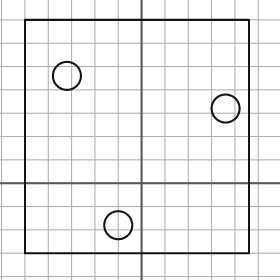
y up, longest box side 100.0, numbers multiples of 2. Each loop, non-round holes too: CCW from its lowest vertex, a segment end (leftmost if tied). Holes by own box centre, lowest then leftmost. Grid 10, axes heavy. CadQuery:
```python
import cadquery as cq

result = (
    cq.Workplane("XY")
    .moveTo(-50.0, -30.0)
    .lineTo(46.0, -30.0)
    .lineTo(46.0, 70.0)
    .lineTo(-50.0, 70.0)
    .close()
    .moveTo(-10.0, -18.0)
    .circle(6.0)
    .moveTo(36.0, 32.0)
    .circle(6.0)
    .moveTo(-32.0, 46.0)
    .circle(6.0)
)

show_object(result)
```